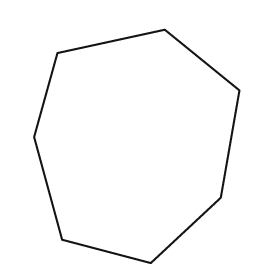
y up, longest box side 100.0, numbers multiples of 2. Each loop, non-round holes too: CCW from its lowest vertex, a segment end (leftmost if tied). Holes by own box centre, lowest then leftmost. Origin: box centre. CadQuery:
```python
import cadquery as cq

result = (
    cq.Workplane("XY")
    .moveTo(6.0, -50.0)
    .lineTo(36.0, -22.0)
    .lineTo(44.0, 24.0)
    .lineTo(12.0, 50.0)
    .lineTo(-34.0, 40.0)
    .lineTo(-44.0, 4.0)
    .lineTo(-32.0, -40.0)
    .close()
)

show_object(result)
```